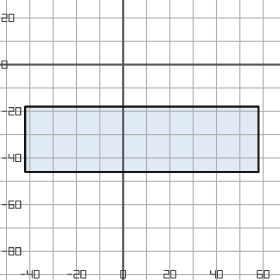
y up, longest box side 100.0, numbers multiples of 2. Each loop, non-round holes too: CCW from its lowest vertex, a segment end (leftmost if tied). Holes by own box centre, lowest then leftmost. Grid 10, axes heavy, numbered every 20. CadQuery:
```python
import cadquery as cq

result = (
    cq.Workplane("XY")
    .moveTo(-42.0, -46.0)
    .lineTo(58.0, -46.0)
    .lineTo(58.0, -18.0)
    .lineTo(-42.0, -18.0)
    .close()
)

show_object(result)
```